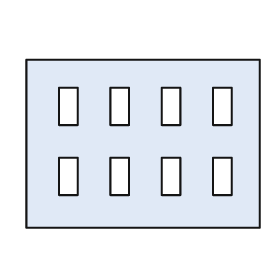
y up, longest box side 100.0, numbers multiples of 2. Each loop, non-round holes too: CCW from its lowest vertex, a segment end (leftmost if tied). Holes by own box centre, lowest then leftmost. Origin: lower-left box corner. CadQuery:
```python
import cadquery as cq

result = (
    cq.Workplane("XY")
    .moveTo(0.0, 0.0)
    .lineTo(100.0, 0.0)
    .lineTo(100.0, 72.0)
    .lineTo(0.0, 72.0)
    .close()
    .moveTo(14.0, 14.0)
    .lineTo(22.0, 14.0)
    .lineTo(22.0, 30.0)
    .lineTo(14.0, 30.0)
    .close()
    .moveTo(36.0, 14.0)
    .lineTo(44.0, 14.0)
    .lineTo(44.0, 30.0)
    .lineTo(36.0, 30.0)
    .close()
    .moveTo(58.0, 14.0)
    .lineTo(66.0, 14.0)
    .lineTo(66.0, 30.0)
    .lineTo(58.0, 30.0)
    .close()
    .moveTo(80.0, 14.0)
    .lineTo(88.0, 14.0)
    .lineTo(88.0, 30.0)
    .lineTo(80.0, 30.0)
    .close()
    .moveTo(14.0, 44.0)
    .lineTo(22.0, 44.0)
    .lineTo(22.0, 60.0)
    .lineTo(14.0, 60.0)
    .close()
    .moveTo(36.0, 44.0)
    .lineTo(44.0, 44.0)
    .lineTo(44.0, 60.0)
    .lineTo(36.0, 60.0)
    .close()
    .moveTo(58.0, 44.0)
    .lineTo(66.0, 44.0)
    .lineTo(66.0, 60.0)
    .lineTo(58.0, 60.0)
    .close()
    .moveTo(80.0, 44.0)
    .lineTo(88.0, 44.0)
    .lineTo(88.0, 60.0)
    .lineTo(80.0, 60.0)
    .close()
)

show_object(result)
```